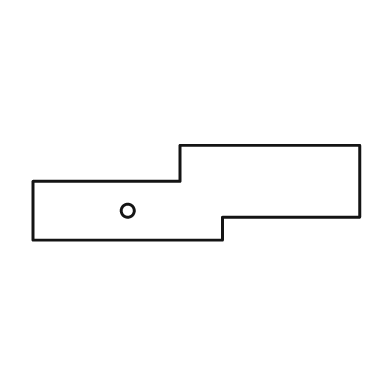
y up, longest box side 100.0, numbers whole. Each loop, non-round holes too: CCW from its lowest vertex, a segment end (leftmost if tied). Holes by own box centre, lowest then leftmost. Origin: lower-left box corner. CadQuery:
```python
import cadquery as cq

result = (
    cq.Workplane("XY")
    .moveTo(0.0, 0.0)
    .lineTo(58.0, 0.0)
    .lineTo(58.0, 7.0)
    .lineTo(100.0, 7.0)
    .lineTo(100.0, 29.0)
    .lineTo(45.0, 29.0)
    .lineTo(45.0, 18.0)
    .lineTo(0.0, 18.0)
    .close()
    .moveTo(29.0, 9.0)
    .circle(2.0)
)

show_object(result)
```